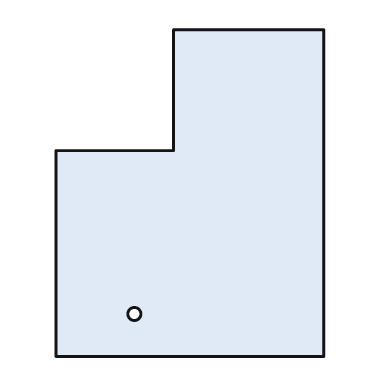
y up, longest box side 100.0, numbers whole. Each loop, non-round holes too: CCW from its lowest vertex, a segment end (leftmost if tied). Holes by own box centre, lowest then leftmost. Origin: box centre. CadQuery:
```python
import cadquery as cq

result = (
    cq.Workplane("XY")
    .moveTo(-41.0, -50.0)
    .lineTo(41.0, -50.0)
    .lineTo(41.0, 50.0)
    .lineTo(-5.0, 50.0)
    .lineTo(-5.0, 13.0)
    .lineTo(-41.0, 13.0)
    .close()
    .moveTo(-17.0, -37.0)
    .circle(2.0)
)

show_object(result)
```